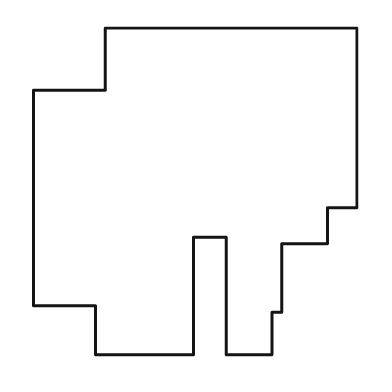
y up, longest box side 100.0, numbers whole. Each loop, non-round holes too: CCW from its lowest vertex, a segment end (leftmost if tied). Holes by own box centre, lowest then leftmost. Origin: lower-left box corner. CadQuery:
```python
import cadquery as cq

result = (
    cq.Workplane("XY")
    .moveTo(19.0, 0.0)
    .lineTo(49.0, 0.0)
    .lineTo(49.0, 36.0)
    .lineTo(59.0, 36.0)
    .lineTo(59.0, 0.0)
    .lineTo(73.0, 0.0)
    .lineTo(73.0, 13.0)
    .lineTo(76.0, 13.0)
    .lineTo(76.0, 34.0)
    .lineTo(90.0, 34.0)
    .lineTo(90.0, 45.0)
    .lineTo(99.0, 45.0)
    .lineTo(99.0, 100.0)
    .lineTo(22.0, 100.0)
    .lineTo(22.0, 81.0)
    .lineTo(0.0, 81.0)
    .lineTo(0.0, 15.0)
    .lineTo(19.0, 15.0)
    .close()
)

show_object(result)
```